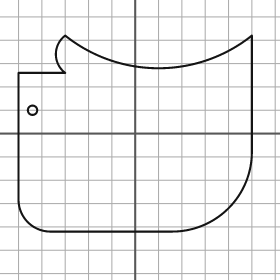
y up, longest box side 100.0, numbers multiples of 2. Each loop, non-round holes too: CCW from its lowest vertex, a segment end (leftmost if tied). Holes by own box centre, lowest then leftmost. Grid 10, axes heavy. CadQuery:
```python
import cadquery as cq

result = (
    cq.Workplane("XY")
    .moveTo(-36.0, -42.0)
    .lineTo(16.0, -42.0)
    .threePointArc((40.0, -32.0), (50.0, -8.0))
    .lineTo(50.0, 42.0)
    .threePointArc((10.0, 28.0), (-30.0, 42.0))
    .threePointArc((-34.0, 34.0), (-30.0, 26.0))
    .lineTo(-50.0, 26.0)
    .lineTo(-50.0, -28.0)
    .threePointArc((-46.0, -38.0), (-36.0, -42.0))
    .close()
    .moveTo(-44.0, 10.0)
    .circle(2.0)
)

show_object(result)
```